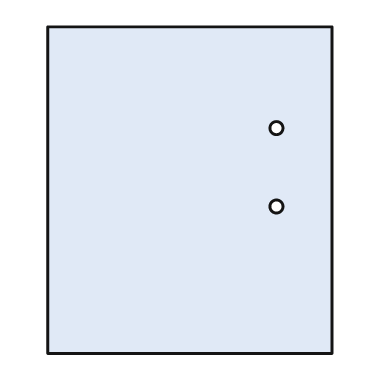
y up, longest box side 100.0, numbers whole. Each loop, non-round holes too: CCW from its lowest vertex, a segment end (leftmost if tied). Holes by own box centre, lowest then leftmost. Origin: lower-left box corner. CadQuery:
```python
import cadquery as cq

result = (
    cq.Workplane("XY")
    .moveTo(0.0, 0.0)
    .lineTo(87.0, 0.0)
    .lineTo(87.0, 100.0)
    .lineTo(0.0, 100.0)
    .close()
    .moveTo(70.0, 45.0)
    .circle(2.0)
    .moveTo(70.0, 69.0)
    .circle(2.0)
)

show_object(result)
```